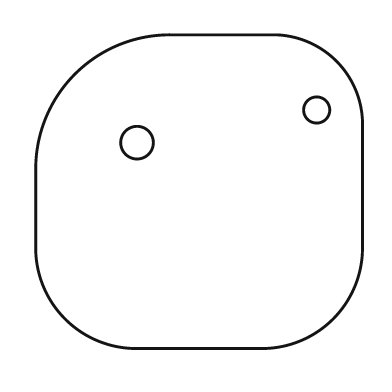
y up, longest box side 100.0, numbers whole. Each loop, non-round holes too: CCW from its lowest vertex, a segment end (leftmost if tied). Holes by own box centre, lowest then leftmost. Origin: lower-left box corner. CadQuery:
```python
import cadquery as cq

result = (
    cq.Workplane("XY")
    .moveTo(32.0, 0.0)
    .lineTo(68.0, 0.0)
    .threePointArc((91.0, 9.0), (100.0, 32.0))
    .lineTo(100.0, 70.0)
    .threePointArc((92.0, 88.0), (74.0, 96.0))
    .lineTo(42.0, 96.0)
    .threePointArc((12.0, 84.0), (0.0, 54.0))
    .lineTo(0.0, 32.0)
    .threePointArc((9.0, 9.0), (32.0, 0.0))
    .close()
    .moveTo(31.0, 63.0)
    .circle(5.0)
    .moveTo(86.0, 73.0)
    .circle(4.0)
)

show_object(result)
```